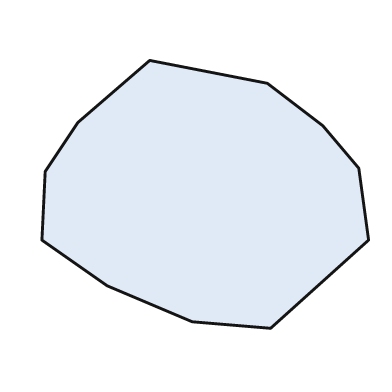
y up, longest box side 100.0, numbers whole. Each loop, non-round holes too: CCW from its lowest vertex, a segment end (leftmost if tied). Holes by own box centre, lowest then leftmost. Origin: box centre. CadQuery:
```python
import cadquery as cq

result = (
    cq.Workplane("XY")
    .moveTo(20.0, -41.0)
    .lineTo(50.0, -14.0)
    .lineTo(47.0, 8.0)
    .lineTo(36.0, 21.0)
    .lineTo(19.0, 34.0)
    .lineTo(-17.0, 41.0)
    .lineTo(-39.0, 22.0)
    .lineTo(-49.0, 7.0)
    .lineTo(-50.0, -14.0)
    .lineTo(-30.0, -28.0)
    .lineTo(-4.0, -39.0)
    .close()
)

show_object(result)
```